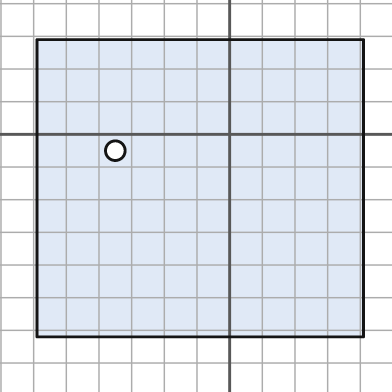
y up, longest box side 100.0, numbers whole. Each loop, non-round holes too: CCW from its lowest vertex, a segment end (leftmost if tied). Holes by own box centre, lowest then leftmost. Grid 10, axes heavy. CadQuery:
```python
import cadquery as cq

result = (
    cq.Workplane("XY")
    .moveTo(-59.0, -62.0)
    .lineTo(41.0, -62.0)
    .lineTo(41.0, 29.0)
    .lineTo(-59.0, 29.0)
    .close()
    .moveTo(-35.0, -5.0)
    .circle(3.0)
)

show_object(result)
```